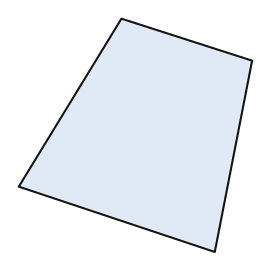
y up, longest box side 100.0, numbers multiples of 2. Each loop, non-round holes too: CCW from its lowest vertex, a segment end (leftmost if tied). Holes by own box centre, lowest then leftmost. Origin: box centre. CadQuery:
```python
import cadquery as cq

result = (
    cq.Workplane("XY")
    .moveTo(34.0, -50.0)
    .lineTo(50.0, 32.0)
    .lineTo(-6.0, 50.0)
    .lineTo(-50.0, -22.0)
    .close()
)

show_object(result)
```